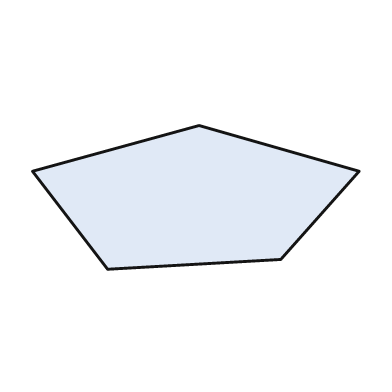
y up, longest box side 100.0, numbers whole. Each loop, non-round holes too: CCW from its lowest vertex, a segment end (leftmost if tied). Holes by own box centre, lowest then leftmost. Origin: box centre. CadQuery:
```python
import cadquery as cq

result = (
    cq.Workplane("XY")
    .moveTo(-27.0, -22.0)
    .lineTo(26.0, -19.0)
    .lineTo(50.0, 8.0)
    .lineTo(1.0, 22.0)
    .lineTo(-50.0, 8.0)
    .close()
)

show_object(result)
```